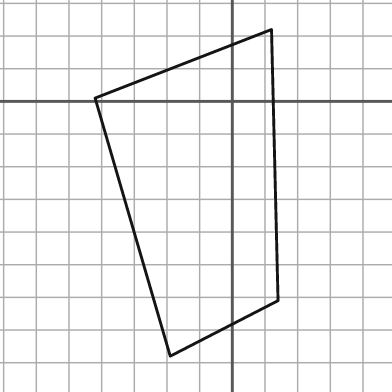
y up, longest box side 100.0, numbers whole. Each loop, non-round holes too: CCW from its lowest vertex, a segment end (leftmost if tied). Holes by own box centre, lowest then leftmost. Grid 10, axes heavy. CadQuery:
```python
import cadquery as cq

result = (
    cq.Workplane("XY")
    .moveTo(-19.0, -78.0)
    .lineTo(14.0, -61.0)
    .lineTo(12.0, 22.0)
    .lineTo(-42.0, 1.0)
    .close()
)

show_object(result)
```